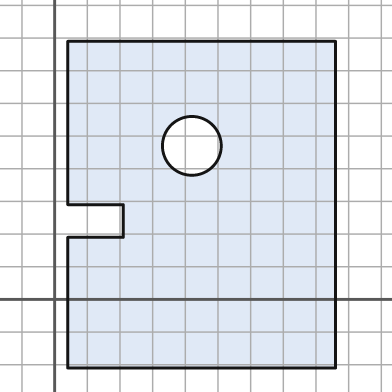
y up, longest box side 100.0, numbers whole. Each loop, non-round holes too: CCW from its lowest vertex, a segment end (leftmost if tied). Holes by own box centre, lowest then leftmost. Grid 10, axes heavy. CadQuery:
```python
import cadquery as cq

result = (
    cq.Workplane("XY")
    .moveTo(4.0, -21.0)
    .lineTo(86.0, -21.0)
    .lineTo(86.0, 79.0)
    .lineTo(4.0, 79.0)
    .lineTo(4.0, 29.0)
    .lineTo(21.0, 29.0)
    .lineTo(21.0, 19.0)
    .lineTo(4.0, 19.0)
    .close()
    .moveTo(42.0, 47.0)
    .circle(9.0)
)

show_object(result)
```